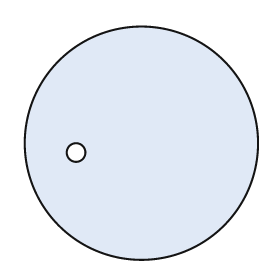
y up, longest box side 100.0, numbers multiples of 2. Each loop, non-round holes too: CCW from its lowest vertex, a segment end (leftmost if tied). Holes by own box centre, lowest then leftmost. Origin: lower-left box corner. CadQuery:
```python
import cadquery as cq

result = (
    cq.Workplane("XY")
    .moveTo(50.0, 50.0)
    .circle(50.0)
    .moveTo(22.0, 46.0)
    .circle(4.0)
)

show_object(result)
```